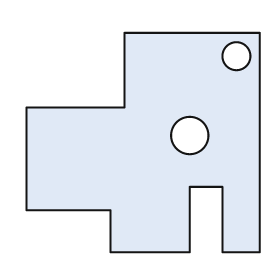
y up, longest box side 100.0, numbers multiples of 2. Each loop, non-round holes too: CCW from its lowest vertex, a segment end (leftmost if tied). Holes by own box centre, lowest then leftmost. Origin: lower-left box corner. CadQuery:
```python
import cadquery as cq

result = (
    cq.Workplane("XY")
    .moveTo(36.0, 0.0)
    .lineTo(70.0, 0.0)
    .lineTo(70.0, 28.0)
    .lineTo(84.0, 28.0)
    .lineTo(84.0, 0.0)
    .lineTo(100.0, 0.0)
    .lineTo(100.0, 94.0)
    .lineTo(42.0, 94.0)
    .lineTo(42.0, 62.0)
    .lineTo(0.0, 62.0)
    .lineTo(0.0, 18.0)
    .lineTo(36.0, 18.0)
    .close()
    .moveTo(70.0, 50.0)
    .circle(8.0)
    .moveTo(90.0, 84.0)
    .circle(6.0)
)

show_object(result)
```